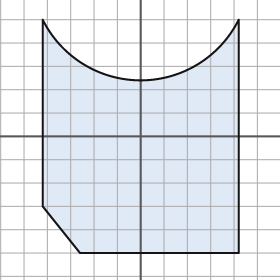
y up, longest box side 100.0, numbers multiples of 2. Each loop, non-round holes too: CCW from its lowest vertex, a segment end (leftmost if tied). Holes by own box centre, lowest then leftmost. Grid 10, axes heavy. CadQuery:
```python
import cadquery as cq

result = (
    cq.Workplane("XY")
    .moveTo(-26.0, -50.0)
    .lineTo(42.0, -50.0)
    .lineTo(42.0, 50.0)
    .threePointArc((0.0, 24.0), (-42.0, 50.0))
    .lineTo(-42.0, -30.0)
    .close()
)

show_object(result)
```